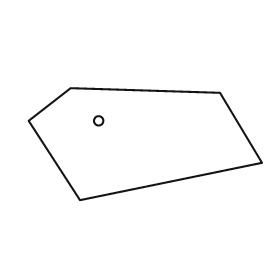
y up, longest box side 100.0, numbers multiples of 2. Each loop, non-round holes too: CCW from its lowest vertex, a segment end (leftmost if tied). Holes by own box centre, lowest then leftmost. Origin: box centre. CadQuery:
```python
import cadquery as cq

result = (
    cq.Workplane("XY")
    .moveTo(-28.0, -24.0)
    .lineTo(50.0, -8.0)
    .lineTo(32.0, 22.0)
    .lineTo(-32.0, 24.0)
    .lineTo(-50.0, 10.0)
    .close()
    .moveTo(-20.0, 10.0)
    .circle(2.0)
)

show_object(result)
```